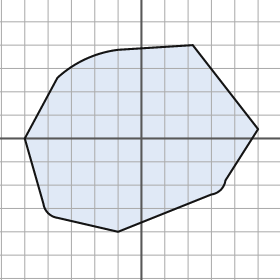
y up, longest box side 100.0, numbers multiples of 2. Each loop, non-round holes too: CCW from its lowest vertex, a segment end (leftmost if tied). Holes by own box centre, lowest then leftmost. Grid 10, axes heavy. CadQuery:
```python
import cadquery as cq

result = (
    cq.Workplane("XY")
    .moveTo(-10.0, -40.0)
    .lineTo(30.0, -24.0)
    .threePointArc((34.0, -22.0), (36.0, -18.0))
    .lineTo(50.0, 4.0)
    .lineTo(22.0, 40.0)
    .lineTo(-10.0, 38.0)
    .threePointArc((-24.0, 34.0), (-36.0, 26.0))
    .lineTo(-50.0, 0.0)
    .lineTo(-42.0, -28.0)
    .threePointArc((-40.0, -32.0), (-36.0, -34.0))
    .close()
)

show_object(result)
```